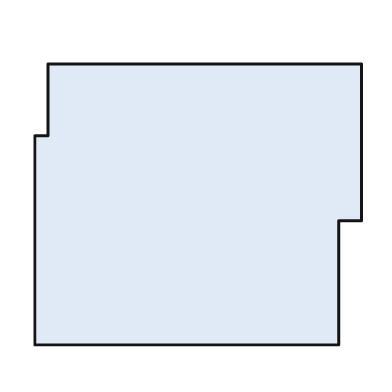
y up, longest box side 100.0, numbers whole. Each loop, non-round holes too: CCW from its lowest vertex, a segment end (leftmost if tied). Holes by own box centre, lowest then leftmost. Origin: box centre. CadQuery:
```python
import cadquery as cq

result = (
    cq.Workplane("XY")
    .moveTo(-50.0, -43.0)
    .lineTo(43.0, -43.0)
    .lineTo(43.0, -5.0)
    .lineTo(50.0, -5.0)
    .lineTo(50.0, 43.0)
    .lineTo(-46.0, 43.0)
    .lineTo(-46.0, 21.0)
    .lineTo(-50.0, 21.0)
    .close()
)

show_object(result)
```